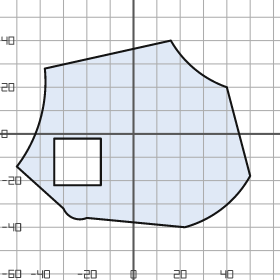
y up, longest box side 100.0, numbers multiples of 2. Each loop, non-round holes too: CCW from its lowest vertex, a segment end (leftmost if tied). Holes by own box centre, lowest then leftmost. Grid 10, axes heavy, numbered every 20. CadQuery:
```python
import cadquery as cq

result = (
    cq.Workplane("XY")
    .moveTo(22.0, -40.0)
    .threePointArc((38.0, -32.0), (50.0, -18.0))
    .lineTo(40.0, 20.0)
    .threePointArc((26.0, 28.0), (16.0, 40.0))
    .lineTo(-38.0, 28.0)
    .threePointArc((-40.0, 6.0), (-50.0, -14.0))
    .lineTo(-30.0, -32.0)
    .threePointArc((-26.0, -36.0), (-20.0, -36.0))
    .close()
    .moveTo(-34.0, -22.0)
    .lineTo(-14.0, -22.0)
    .lineTo(-14.0, -2.0)
    .lineTo(-34.0, -2.0)
    .close()
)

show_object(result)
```